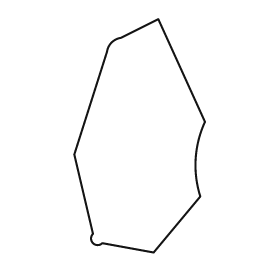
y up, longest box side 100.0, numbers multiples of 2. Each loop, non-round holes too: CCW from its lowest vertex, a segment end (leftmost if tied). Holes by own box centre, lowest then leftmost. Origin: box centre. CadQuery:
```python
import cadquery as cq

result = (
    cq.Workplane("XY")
    .moveTo(6.0, -50.0)
    .lineTo(26.0, -26.0)
    .threePointArc((24.0, -10.0), (28.0, 6.0))
    .lineTo(8.0, 50.0)
    .lineTo(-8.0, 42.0)
    .threePointArc((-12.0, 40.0), (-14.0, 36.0))
    .lineTo(-28.0, -8.0)
    .lineTo(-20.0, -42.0)
    .threePointArc((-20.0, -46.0), (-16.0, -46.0))
    .close()
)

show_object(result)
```